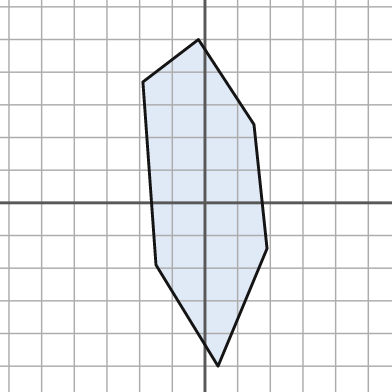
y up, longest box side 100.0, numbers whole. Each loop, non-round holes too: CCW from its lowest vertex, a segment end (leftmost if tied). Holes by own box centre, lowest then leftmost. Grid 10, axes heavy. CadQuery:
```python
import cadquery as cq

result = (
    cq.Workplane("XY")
    .moveTo(4.0, -50.0)
    .lineTo(19.0, -14.0)
    .lineTo(15.0, 24.0)
    .lineTo(-2.0, 50.0)
    .lineTo(-19.0, 37.0)
    .lineTo(-15.0, -19.0)
    .close()
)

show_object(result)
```